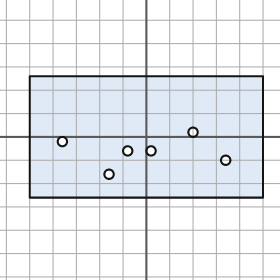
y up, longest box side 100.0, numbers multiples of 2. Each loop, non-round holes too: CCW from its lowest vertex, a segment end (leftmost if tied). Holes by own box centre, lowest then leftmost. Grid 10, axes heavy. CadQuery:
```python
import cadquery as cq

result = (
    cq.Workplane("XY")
    .moveTo(-50.0, -26.0)
    .lineTo(50.0, -26.0)
    .lineTo(50.0, 26.0)
    .lineTo(-50.0, 26.0)
    .close()
    .moveTo(-16.0, -16.0)
    .circle(2.0)
    .moveTo(34.0, -10.0)
    .circle(2.0)
    .moveTo(-8.0, -6.0)
    .circle(2.0)
    .moveTo(2.0, -6.0)
    .circle(2.0)
    .moveTo(-36.0, -2.0)
    .circle(2.0)
    .moveTo(20.0, 2.0)
    .circle(2.0)
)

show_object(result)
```